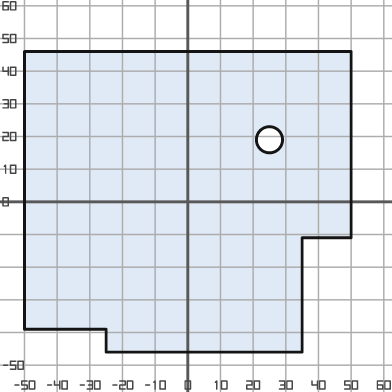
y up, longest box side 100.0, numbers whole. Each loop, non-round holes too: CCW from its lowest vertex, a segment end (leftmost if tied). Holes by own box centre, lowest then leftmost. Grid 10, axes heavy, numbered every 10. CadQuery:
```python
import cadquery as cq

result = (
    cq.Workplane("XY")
    .moveTo(-25.0, -46.0)
    .lineTo(35.0, -46.0)
    .lineTo(35.0, -11.0)
    .lineTo(50.0, -11.0)
    .lineTo(50.0, 46.0)
    .lineTo(-50.0, 46.0)
    .lineTo(-50.0, -39.0)
    .lineTo(-25.0, -39.0)
    .close()
    .moveTo(25.0, 19.0)
    .circle(4.0)
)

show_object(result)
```